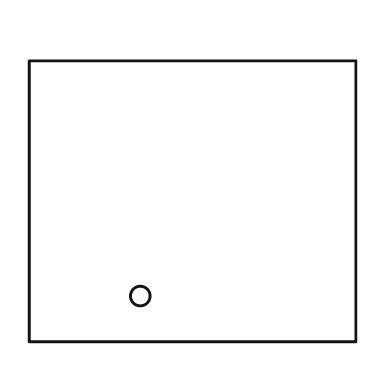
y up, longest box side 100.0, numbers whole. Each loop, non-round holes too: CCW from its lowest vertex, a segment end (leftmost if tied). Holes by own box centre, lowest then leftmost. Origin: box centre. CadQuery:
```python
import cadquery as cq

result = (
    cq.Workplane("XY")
    .moveTo(-50.0, -43.0)
    .lineTo(50.0, -43.0)
    .lineTo(50.0, 43.0)
    .lineTo(-50.0, 43.0)
    .close()
    .moveTo(-16.0, -29.0)
    .circle(3.0)
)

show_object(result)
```